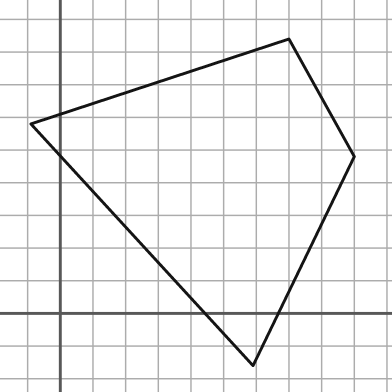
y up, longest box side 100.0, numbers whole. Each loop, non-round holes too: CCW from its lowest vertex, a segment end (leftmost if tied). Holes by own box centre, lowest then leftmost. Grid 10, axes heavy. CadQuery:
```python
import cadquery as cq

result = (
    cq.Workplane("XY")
    .moveTo(59.0, -16.0)
    .lineTo(90.0, 48.0)
    .lineTo(70.0, 84.0)
    .lineTo(-9.0, 58.0)
    .close()
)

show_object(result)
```